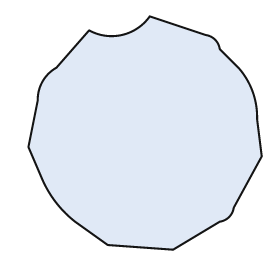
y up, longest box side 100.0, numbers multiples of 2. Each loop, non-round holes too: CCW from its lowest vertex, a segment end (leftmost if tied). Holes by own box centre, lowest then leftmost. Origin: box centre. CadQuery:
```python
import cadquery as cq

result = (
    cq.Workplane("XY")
    .moveTo(12.0, -50.0)
    .lineTo(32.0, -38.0)
    .threePointArc((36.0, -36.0), (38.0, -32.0))
    .lineTo(50.0, -10.0)
    .lineTo(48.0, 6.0)
    .threePointArc((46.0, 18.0), (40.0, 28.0))
    .lineTo(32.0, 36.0)
    .threePointArc((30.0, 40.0), (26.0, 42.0))
    .lineTo(2.0, 50.0)
    .threePointArc((-10.0, 42.0), (-24.0, 44.0))
    .lineTo(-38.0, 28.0)
    .threePointArc((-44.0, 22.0), (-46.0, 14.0))
    .lineTo(-50.0, -6.0)
    .lineTo(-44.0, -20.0)
    .threePointArc((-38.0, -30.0), (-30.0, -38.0))
    .lineTo(-16.0, -48.0)
    .close()
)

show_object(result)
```